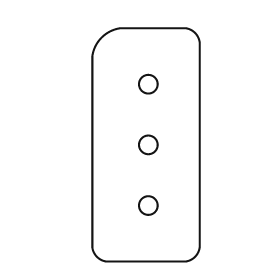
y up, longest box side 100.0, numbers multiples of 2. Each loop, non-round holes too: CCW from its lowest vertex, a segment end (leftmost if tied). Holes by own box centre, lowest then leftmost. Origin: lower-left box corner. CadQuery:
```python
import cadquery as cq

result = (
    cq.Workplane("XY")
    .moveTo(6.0, 0.0)
    .lineTo(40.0, 0.0)
    .threePointArc((44.0, 2.0), (46.0, 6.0))
    .lineTo(46.0, 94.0)
    .threePointArc((44.0, 98.0), (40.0, 100.0))
    .lineTo(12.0, 100.0)
    .threePointArc((4.0, 96.0), (0.0, 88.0))
    .lineTo(0.0, 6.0)
    .threePointArc((2.0, 2.0), (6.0, 0.0))
    .close()
    .moveTo(24.0, 24.0)
    .circle(4.0)
    .moveTo(24.0, 50.0)
    .circle(4.0)
    .moveTo(24.0, 76.0)
    .circle(4.0)
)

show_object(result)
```